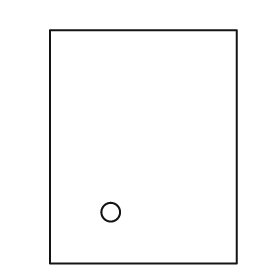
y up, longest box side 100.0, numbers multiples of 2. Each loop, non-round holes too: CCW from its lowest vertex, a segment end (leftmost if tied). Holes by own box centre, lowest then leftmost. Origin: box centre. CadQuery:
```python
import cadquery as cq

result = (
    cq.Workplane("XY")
    .moveTo(-40.0, -50.0)
    .lineTo(40.0, -50.0)
    .lineTo(40.0, 50.0)
    .lineTo(-40.0, 50.0)
    .close()
    .moveTo(-14.0, -28.0)
    .circle(4.0)
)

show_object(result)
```